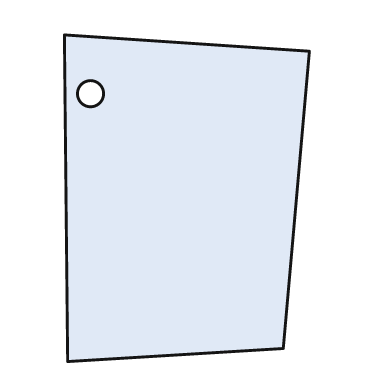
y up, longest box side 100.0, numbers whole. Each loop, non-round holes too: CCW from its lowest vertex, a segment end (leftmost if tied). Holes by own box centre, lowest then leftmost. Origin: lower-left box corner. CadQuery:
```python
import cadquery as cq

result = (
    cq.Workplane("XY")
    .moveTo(1.0, 0.0)
    .lineTo(67.0, 4.0)
    .lineTo(75.0, 95.0)
    .lineTo(0.0, 100.0)
    .close()
    .moveTo(8.0, 82.0)
    .circle(4.0)
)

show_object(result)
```